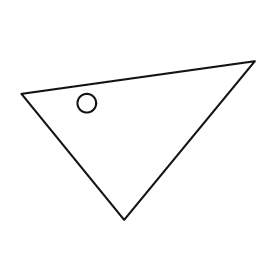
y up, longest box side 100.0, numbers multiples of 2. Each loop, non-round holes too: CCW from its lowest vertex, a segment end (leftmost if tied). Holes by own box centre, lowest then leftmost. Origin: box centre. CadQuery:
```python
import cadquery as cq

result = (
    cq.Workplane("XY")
    .moveTo(-6.0, -34.0)
    .lineTo(50.0, 34.0)
    .lineTo(-50.0, 20.0)
    .close()
    .moveTo(-22.0, 16.0)
    .circle(4.0)
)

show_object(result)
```